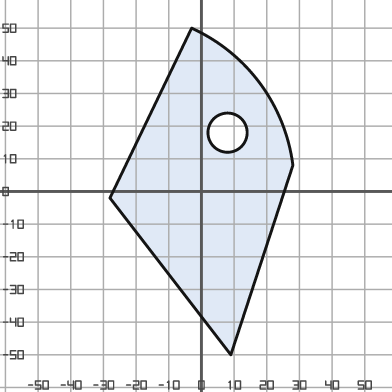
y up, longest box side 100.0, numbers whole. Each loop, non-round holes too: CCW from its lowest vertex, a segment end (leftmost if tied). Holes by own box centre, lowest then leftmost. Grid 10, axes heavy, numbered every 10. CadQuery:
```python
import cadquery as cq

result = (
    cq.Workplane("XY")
    .moveTo(9.0, -50.0)
    .lineTo(28.0, 8.0)
    .threePointArc((18.0, 33.0), (-3.0, 50.0))
    .lineTo(-28.0, -2.0)
    .close()
    .moveTo(8.0, 18.0)
    .circle(6.0)
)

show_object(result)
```